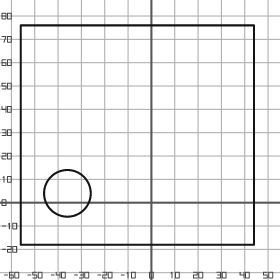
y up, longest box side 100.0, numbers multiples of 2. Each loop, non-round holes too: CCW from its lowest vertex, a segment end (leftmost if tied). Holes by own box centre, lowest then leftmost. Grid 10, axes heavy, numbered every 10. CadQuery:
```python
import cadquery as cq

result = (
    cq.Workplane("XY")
    .moveTo(-56.0, -18.0)
    .lineTo(44.0, -18.0)
    .lineTo(44.0, 76.0)
    .lineTo(-56.0, 76.0)
    .close()
    .moveTo(-36.0, 4.0)
    .circle(10.0)
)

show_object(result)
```